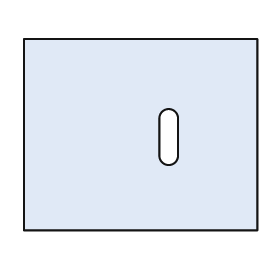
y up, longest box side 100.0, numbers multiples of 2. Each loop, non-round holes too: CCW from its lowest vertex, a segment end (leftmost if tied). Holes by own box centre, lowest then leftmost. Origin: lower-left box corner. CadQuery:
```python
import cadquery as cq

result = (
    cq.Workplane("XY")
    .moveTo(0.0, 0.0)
    .lineTo(100.0, 0.0)
    .lineTo(100.0, 82.0)
    .lineTo(0.0, 82.0)
    .close()
    .moveTo(58.0, 32.0)
    .threePointArc((62.0, 28.0), (66.0, 32.0))
    .lineTo(66.0, 48.0)
    .threePointArc((62.0, 52.0), (58.0, 48.0))
    .close()
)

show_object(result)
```